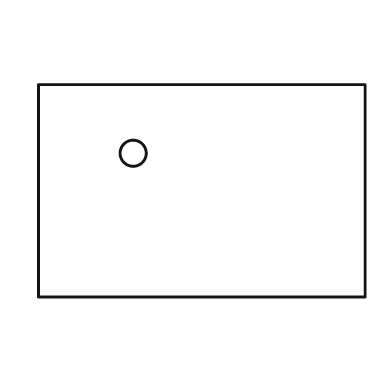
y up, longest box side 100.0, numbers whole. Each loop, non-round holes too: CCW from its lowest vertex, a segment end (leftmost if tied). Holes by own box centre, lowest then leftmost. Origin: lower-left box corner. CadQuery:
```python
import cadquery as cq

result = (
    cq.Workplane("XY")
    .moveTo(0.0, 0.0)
    .lineTo(100.0, 0.0)
    .lineTo(100.0, 65.0)
    .lineTo(0.0, 65.0)
    .close()
    .moveTo(29.0, 44.0)
    .circle(4.0)
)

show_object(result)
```